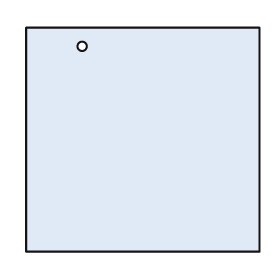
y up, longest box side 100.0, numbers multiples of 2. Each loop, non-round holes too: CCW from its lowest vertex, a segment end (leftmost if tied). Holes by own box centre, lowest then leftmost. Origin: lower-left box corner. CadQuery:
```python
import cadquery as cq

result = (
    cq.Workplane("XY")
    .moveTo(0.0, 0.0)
    .lineTo(100.0, 0.0)
    .lineTo(100.0, 96.0)
    .lineTo(0.0, 96.0)
    .close()
    .moveTo(24.0, 88.0)
    .circle(2.0)
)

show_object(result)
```